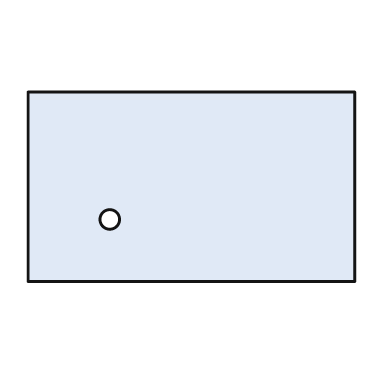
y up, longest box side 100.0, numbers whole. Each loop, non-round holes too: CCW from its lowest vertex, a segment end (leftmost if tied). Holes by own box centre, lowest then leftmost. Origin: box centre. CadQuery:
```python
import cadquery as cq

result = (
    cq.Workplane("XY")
    .moveTo(-50.0, -29.0)
    .lineTo(50.0, -29.0)
    .lineTo(50.0, 29.0)
    .lineTo(-50.0, 29.0)
    .close()
    .moveTo(-25.0, -10.0)
    .circle(3.0)
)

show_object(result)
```